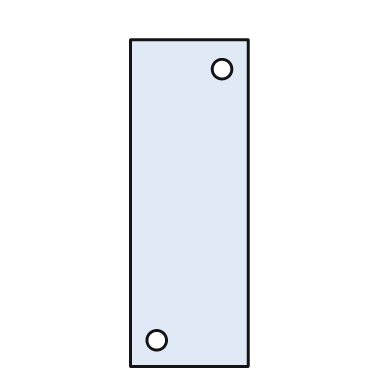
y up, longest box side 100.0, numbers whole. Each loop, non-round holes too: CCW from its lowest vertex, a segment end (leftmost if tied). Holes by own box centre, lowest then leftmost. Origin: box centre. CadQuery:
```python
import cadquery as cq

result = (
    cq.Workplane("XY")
    .moveTo(-18.0, -50.0)
    .lineTo(18.0, -50.0)
    .lineTo(18.0, 50.0)
    .lineTo(-18.0, 50.0)
    .close()
    .moveTo(-10.0, -42.0)
    .circle(3.0)
    .moveTo(10.0, 41.0)
    .circle(3.0)
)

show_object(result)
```